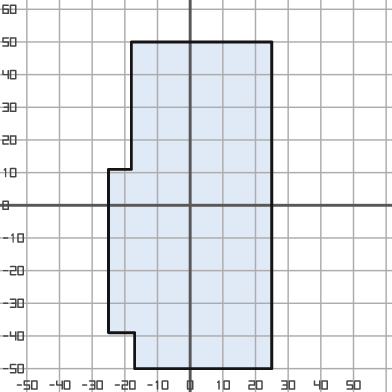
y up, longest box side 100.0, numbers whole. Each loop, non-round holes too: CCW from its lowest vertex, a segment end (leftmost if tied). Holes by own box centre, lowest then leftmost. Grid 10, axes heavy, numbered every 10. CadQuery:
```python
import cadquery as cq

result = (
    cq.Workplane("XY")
    .moveTo(-17.0, -50.0)
    .lineTo(25.0, -50.0)
    .lineTo(25.0, 50.0)
    .lineTo(-18.0, 50.0)
    .lineTo(-18.0, 11.0)
    .lineTo(-25.0, 11.0)
    .lineTo(-25.0, -39.0)
    .lineTo(-17.0, -39.0)
    .close()
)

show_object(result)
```